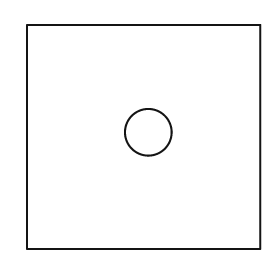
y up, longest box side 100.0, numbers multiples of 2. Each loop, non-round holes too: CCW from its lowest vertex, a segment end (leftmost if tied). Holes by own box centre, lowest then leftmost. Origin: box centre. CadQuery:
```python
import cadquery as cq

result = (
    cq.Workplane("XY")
    .moveTo(-50.0, -48.0)
    .lineTo(50.0, -48.0)
    .lineTo(50.0, 48.0)
    .lineTo(-50.0, 48.0)
    .close()
    .moveTo(2.0, 2.0)
    .circle(10.0)
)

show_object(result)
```